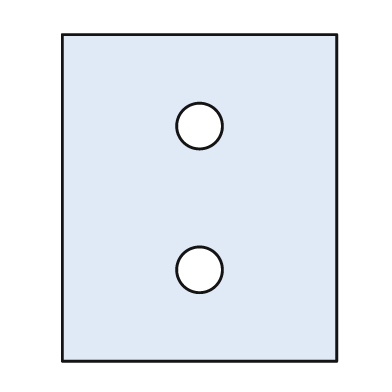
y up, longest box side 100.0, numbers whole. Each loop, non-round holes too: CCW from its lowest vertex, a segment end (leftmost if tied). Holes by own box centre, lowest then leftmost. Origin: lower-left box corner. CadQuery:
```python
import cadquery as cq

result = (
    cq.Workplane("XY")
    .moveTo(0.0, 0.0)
    .lineTo(84.0, 0.0)
    .lineTo(84.0, 100.0)
    .lineTo(0.0, 100.0)
    .close()
    .moveTo(42.0, 28.0)
    .circle(7.0)
    .moveTo(42.0, 72.0)
    .circle(7.0)
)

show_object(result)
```